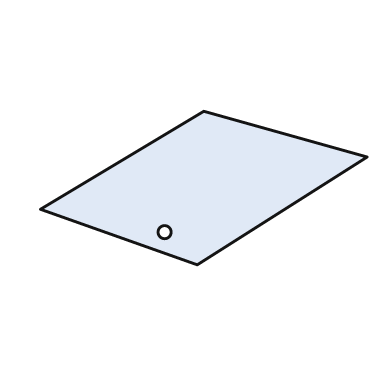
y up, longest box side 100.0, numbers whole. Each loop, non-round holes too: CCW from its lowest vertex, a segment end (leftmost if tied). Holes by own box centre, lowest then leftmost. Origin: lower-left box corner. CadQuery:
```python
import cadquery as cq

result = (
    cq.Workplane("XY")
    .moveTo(48.0, 0.0)
    .lineTo(100.0, 33.0)
    .lineTo(50.0, 47.0)
    .lineTo(0.0, 17.0)
    .close()
    .moveTo(38.0, 10.0)
    .circle(2.0)
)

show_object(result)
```